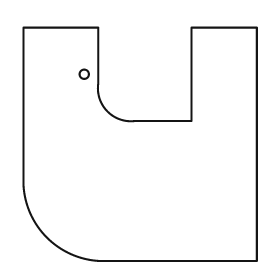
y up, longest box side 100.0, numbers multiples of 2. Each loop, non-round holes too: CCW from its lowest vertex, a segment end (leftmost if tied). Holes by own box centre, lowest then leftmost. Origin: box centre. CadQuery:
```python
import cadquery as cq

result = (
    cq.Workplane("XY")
    .moveTo(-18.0, -50.0)
    .lineTo(50.0, -50.0)
    .lineTo(50.0, 50.0)
    .lineTo(22.0, 50.0)
    .lineTo(22.0, 10.0)
    .lineTo(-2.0, 10.0)
    .threePointArc((-14.0, 14.0), (-18.0, 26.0))
    .lineTo(-18.0, 50.0)
    .lineTo(-50.0, 50.0)
    .lineTo(-50.0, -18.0)
    .threePointArc((-40.0, -40.0), (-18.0, -50.0))
    .close()
    .moveTo(-24.0, 30.0)
    .circle(2.0)
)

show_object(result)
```